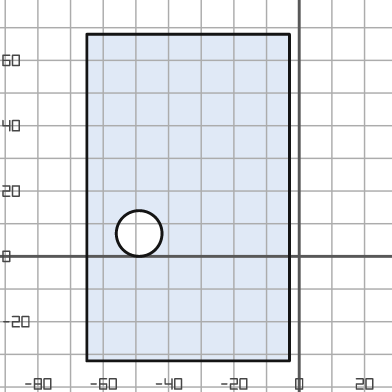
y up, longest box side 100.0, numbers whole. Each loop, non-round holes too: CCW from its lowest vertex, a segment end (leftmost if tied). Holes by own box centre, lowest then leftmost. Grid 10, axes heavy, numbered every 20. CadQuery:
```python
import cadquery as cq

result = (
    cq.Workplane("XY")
    .moveTo(-65.0, -32.0)
    .lineTo(-3.0, -32.0)
    .lineTo(-3.0, 68.0)
    .lineTo(-65.0, 68.0)
    .close()
    .moveTo(-49.0, 7.0)
    .circle(7.0)
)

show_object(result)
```